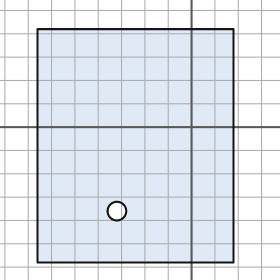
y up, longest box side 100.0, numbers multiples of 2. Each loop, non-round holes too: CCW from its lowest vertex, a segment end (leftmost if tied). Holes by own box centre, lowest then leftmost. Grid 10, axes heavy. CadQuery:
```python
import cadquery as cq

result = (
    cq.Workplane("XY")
    .moveTo(-66.0, -58.0)
    .lineTo(18.0, -58.0)
    .lineTo(18.0, 42.0)
    .lineTo(-66.0, 42.0)
    .close()
    .moveTo(-32.0, -36.0)
    .circle(4.0)
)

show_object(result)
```